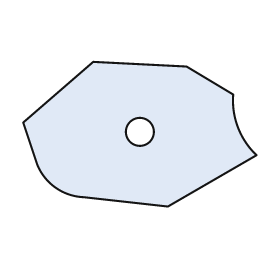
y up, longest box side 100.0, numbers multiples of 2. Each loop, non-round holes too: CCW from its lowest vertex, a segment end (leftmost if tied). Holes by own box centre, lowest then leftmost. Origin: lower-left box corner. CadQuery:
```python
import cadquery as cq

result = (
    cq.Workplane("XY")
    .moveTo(62.0, 0.0)
    .lineTo(100.0, 22.0)
    .threePointArc((92.0, 34.0), (90.0, 48.0))
    .lineTo(70.0, 60.0)
    .lineTo(30.0, 62.0)
    .lineTo(0.0, 36.0)
    .lineTo(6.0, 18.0)
    .threePointArc((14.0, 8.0), (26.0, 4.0))
    .close()
    .moveTo(50.0, 32.0)
    .circle(6.0)
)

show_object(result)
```